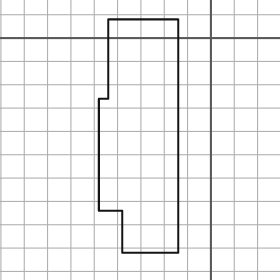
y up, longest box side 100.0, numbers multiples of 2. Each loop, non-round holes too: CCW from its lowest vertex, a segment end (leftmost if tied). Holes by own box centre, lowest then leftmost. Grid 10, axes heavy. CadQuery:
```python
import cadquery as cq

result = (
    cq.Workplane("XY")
    .moveTo(-38.0, -92.0)
    .lineTo(-14.0, -92.0)
    .lineTo(-14.0, 8.0)
    .lineTo(-44.0, 8.0)
    .lineTo(-44.0, -26.0)
    .lineTo(-48.0, -26.0)
    .lineTo(-48.0, -74.0)
    .lineTo(-38.0, -74.0)
    .close()
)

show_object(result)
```